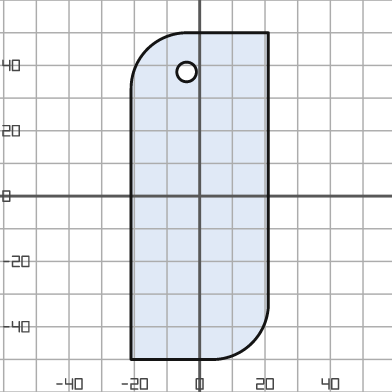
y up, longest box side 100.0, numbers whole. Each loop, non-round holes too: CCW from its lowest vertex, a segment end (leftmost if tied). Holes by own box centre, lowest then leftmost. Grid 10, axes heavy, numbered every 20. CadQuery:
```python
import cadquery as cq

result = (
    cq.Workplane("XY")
    .moveTo(-21.0, -50.0)
    .lineTo(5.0, -50.0)
    .threePointArc((16.0, -45.0), (21.0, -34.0))
    .lineTo(21.0, 50.0)
    .lineTo(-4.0, 50.0)
    .threePointArc((-16.0, 45.0), (-21.0, 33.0))
    .close()
    .moveTo(-4.0, 38.0)
    .circle(3.0)
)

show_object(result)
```